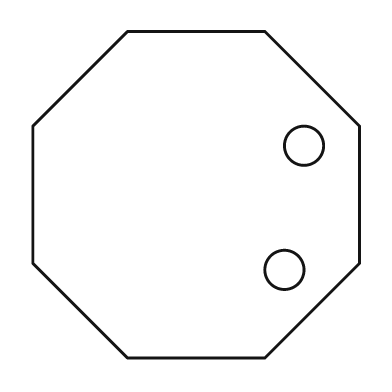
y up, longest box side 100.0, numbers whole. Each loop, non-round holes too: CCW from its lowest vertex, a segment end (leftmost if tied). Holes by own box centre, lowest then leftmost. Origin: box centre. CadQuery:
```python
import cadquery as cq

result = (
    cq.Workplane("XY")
    .moveTo(-21.0, -50.0)
    .lineTo(21.0, -50.0)
    .lineTo(50.0, -21.0)
    .lineTo(50.0, 21.0)
    .lineTo(21.0, 50.0)
    .lineTo(-21.0, 50.0)
    .lineTo(-50.0, 21.0)
    .lineTo(-50.0, -21.0)
    .close()
    .moveTo(27.0, -23.0)
    .circle(6.0)
    .moveTo(33.0, 15.0)
    .circle(6.0)
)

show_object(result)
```